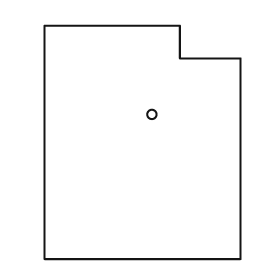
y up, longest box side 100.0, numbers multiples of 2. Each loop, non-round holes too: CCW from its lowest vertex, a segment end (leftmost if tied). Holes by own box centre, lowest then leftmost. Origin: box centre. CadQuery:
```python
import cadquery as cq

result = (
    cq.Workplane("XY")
    .moveTo(-42.0, -50.0)
    .lineTo(42.0, -50.0)
    .lineTo(42.0, 36.0)
    .lineTo(16.0, 36.0)
    .lineTo(16.0, 50.0)
    .lineTo(-42.0, 50.0)
    .close()
    .moveTo(4.0, 12.0)
    .circle(2.0)
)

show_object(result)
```